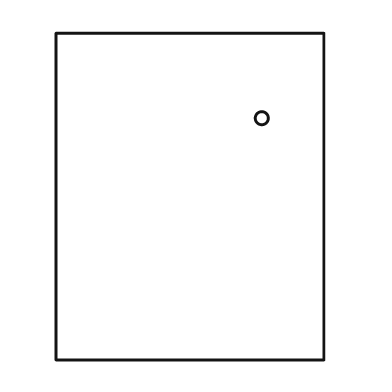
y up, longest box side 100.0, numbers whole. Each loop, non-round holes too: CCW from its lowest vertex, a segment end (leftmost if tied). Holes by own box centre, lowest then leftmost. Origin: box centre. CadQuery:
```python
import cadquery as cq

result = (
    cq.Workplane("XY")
    .moveTo(-41.0, -50.0)
    .lineTo(41.0, -50.0)
    .lineTo(41.0, 50.0)
    .lineTo(-41.0, 50.0)
    .close()
    .moveTo(22.0, 24.0)
    .circle(2.0)
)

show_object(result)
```